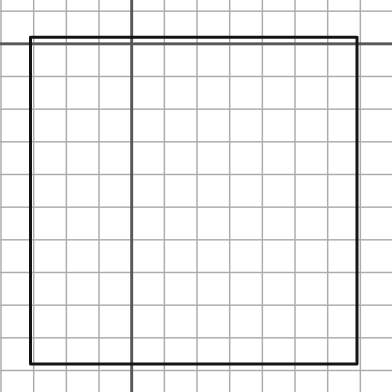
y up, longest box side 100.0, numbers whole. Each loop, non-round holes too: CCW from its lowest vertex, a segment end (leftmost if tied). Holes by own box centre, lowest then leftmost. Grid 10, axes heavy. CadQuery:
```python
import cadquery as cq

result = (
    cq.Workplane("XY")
    .moveTo(-31.0, -98.0)
    .lineTo(69.0, -98.0)
    .lineTo(69.0, 2.0)
    .lineTo(-31.0, 2.0)
    .close()
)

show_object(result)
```